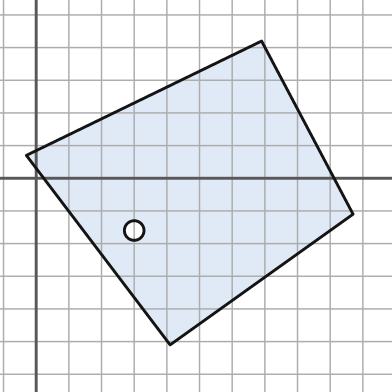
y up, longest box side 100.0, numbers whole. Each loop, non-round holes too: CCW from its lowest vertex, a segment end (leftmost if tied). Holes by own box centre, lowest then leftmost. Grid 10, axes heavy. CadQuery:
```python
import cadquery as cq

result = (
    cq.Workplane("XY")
    .moveTo(41.0, -51.0)
    .lineTo(97.0, -11.0)
    .lineTo(69.0, 42.0)
    .lineTo(-3.0, 7.0)
    .close()
    .moveTo(30.0, -16.0)
    .circle(3.0)
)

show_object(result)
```